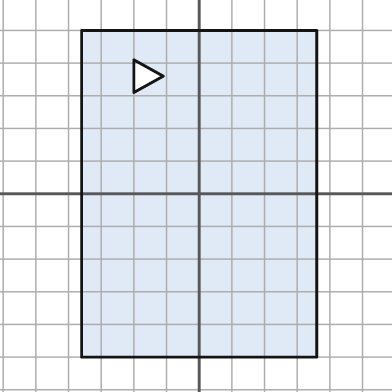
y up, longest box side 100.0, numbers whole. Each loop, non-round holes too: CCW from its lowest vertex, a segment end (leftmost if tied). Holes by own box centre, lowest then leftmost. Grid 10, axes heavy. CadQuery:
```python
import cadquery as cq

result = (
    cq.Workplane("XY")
    .moveTo(-36.0, -50.0)
    .lineTo(36.0, -50.0)
    .lineTo(36.0, 50.0)
    .lineTo(-36.0, 50.0)
    .close()
    .moveTo(-20.0, 31.0)
    .lineTo(-11.0, 36.0)
    .lineTo(-20.0, 41.0)
    .close()
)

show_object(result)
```